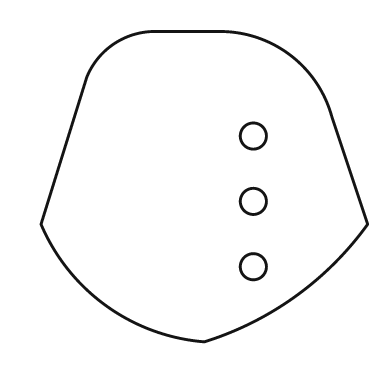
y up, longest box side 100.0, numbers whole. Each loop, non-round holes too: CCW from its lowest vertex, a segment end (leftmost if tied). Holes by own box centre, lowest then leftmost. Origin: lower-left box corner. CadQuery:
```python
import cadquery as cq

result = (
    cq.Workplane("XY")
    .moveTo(50.0, 0.0)
    .threePointArc((78.0, 14.0), (100.0, 36.0))
    .lineTo(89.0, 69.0)
    .threePointArc((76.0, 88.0), (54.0, 95.0))
    .lineTo(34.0, 95.0)
    .threePointArc((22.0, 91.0), (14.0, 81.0))
    .lineTo(0.0, 36.0)
    .threePointArc((20.0, 11.0), (50.0, 0.0))
    .close()
    .moveTo(65.0, 23.0)
    .circle(4.0)
    .moveTo(65.0, 43.0)
    .circle(4.0)
    .moveTo(65.0, 63.0)
    .circle(4.0)
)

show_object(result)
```